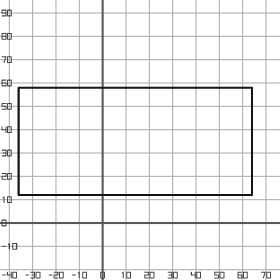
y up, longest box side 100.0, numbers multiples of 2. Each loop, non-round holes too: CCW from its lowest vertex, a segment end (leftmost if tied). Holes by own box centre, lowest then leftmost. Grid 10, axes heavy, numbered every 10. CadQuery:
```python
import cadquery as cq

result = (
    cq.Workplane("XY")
    .moveTo(-36.0, 12.0)
    .lineTo(64.0, 12.0)
    .lineTo(64.0, 58.0)
    .lineTo(-36.0, 58.0)
    .close()
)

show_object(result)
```